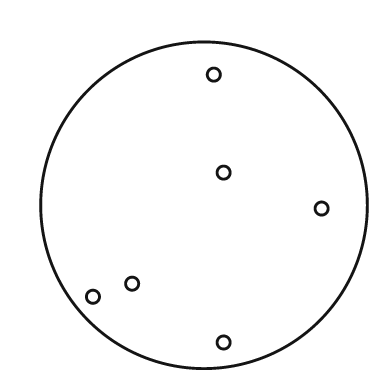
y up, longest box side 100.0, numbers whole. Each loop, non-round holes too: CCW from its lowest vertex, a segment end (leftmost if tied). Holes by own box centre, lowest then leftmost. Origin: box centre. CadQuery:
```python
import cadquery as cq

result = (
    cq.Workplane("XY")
    .moveTo(0.0, 0.0)
    .circle(50.0)
    .moveTo(6.0, -42.0)
    .circle(2.0)
    .moveTo(-34.0, -28.0)
    .circle(2.0)
    .moveTo(-22.0, -24.0)
    .circle(2.0)
    .moveTo(36.0, -1.0)
    .circle(2.0)
    .moveTo(6.0, 10.0)
    .circle(2.0)
    .moveTo(3.0, 40.0)
    .circle(2.0)
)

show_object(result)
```